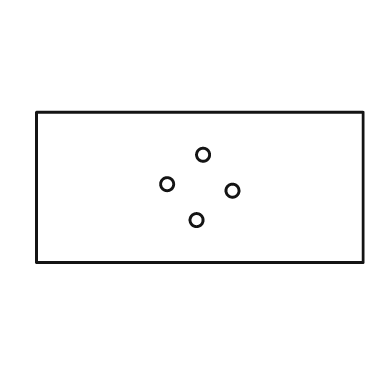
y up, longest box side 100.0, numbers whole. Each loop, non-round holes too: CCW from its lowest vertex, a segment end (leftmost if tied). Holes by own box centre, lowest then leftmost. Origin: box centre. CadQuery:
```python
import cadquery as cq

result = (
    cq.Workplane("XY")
    .moveTo(-50.0, -23.0)
    .lineTo(50.0, -23.0)
    .lineTo(50.0, 23.0)
    .lineTo(-50.0, 23.0)
    .close()
    .moveTo(-1.0, -10.0)
    .circle(2.0)
    .moveTo(10.0, -1.0)
    .circle(2.0)
    .moveTo(-10.0, 1.0)
    .circle(2.0)
    .moveTo(1.0, 10.0)
    .circle(2.0)
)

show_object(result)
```